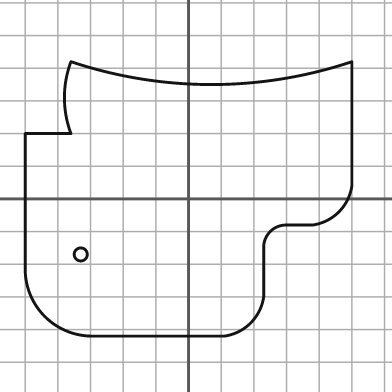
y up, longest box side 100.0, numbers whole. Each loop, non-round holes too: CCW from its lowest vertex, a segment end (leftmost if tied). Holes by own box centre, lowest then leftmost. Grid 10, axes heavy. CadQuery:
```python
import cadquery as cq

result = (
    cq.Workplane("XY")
    .moveTo(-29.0, -42.0)
    .lineTo(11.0, -42.0)
    .threePointArc((19.0, -38.0), (23.0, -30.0))
    .lineTo(23.0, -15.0)
    .threePointArc((25.0, -10.0), (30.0, -8.0))
    .lineTo(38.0, -8.0)
    .threePointArc((46.0, -4.0), (50.0, 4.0))
    .lineTo(50.0, 42.0)
    .threePointArc((7.0, 35.0), (-36.0, 42.0))
    .threePointArc((-38.0, 31.0), (-36.0, 20.0))
    .lineTo(-50.0, 20.0)
    .lineTo(-50.0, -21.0)
    .threePointArc((-44.0, -36.0), (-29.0, -42.0))
    .close()
    .moveTo(-33.0, -17.0)
    .circle(2.0)
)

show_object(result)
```